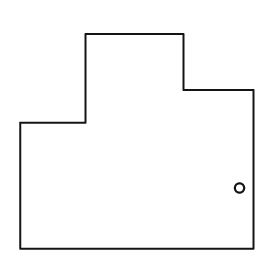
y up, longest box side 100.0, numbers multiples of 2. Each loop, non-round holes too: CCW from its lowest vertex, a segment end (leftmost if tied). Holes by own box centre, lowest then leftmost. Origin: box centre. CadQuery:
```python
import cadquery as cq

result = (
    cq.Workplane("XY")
    .moveTo(-50.0, -46.0)
    .lineTo(50.0, -46.0)
    .lineTo(50.0, 22.0)
    .lineTo(20.0, 22.0)
    .lineTo(20.0, 46.0)
    .lineTo(-22.0, 46.0)
    .lineTo(-22.0, 8.0)
    .lineTo(-50.0, 8.0)
    .close()
    .moveTo(44.0, -20.0)
    .circle(2.0)
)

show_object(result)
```